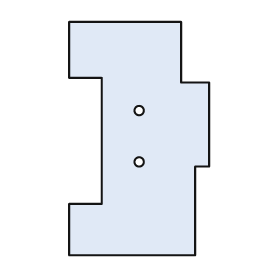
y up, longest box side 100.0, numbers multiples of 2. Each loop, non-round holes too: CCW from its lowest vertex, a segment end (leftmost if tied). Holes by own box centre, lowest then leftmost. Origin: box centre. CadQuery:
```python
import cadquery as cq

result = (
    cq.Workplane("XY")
    .moveTo(-30.0, -50.0)
    .lineTo(24.0, -50.0)
    .lineTo(24.0, -12.0)
    .lineTo(30.0, -12.0)
    .lineTo(30.0, 24.0)
    .lineTo(18.0, 24.0)
    .lineTo(18.0, 50.0)
    .lineTo(-30.0, 50.0)
    .lineTo(-30.0, 26.0)
    .lineTo(-16.0, 26.0)
    .lineTo(-16.0, -28.0)
    .lineTo(-30.0, -28.0)
    .close()
    .moveTo(0.0, -10.0)
    .circle(2.0)
    .moveTo(0.0, 12.0)
    .circle(2.0)
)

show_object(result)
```